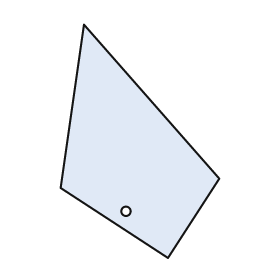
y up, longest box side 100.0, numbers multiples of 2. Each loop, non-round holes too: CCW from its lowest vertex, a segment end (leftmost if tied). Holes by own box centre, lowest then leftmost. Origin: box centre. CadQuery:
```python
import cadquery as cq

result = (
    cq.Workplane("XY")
    .moveTo(12.0, -50.0)
    .lineTo(34.0, -16.0)
    .lineTo(-24.0, 50.0)
    .lineTo(-34.0, -20.0)
    .close()
    .moveTo(-6.0, -30.0)
    .circle(2.0)
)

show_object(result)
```